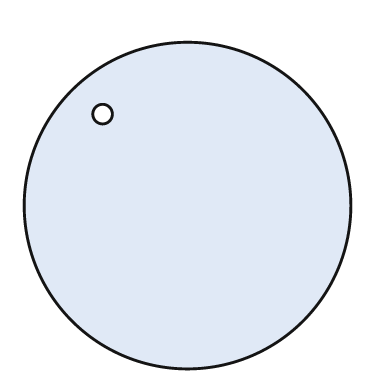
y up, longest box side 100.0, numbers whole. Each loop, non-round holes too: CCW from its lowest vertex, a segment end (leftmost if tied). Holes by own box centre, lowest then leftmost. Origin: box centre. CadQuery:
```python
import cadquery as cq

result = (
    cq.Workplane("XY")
    .moveTo(0.0, 0.0)
    .circle(50.0)
    .moveTo(-26.0, 28.0)
    .circle(3.0)
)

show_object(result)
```